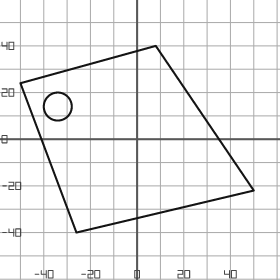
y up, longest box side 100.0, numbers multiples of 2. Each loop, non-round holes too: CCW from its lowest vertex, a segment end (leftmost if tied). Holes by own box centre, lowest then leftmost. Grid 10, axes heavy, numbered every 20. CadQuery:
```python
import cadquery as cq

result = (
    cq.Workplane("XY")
    .moveTo(-26.0, -40.0)
    .lineTo(50.0, -22.0)
    .lineTo(8.0, 40.0)
    .lineTo(-50.0, 24.0)
    .close()
    .moveTo(-34.0, 14.0)
    .circle(6.0)
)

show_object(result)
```